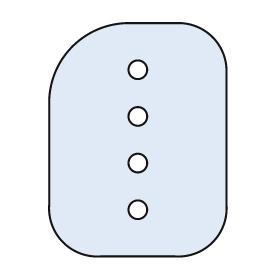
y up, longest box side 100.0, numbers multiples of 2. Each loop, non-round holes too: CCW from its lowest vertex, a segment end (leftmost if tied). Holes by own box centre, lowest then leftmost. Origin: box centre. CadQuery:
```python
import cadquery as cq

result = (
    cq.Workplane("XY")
    .moveTo(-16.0, -50.0)
    .lineTo(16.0, -50.0)
    .threePointArc((32.0, -44.0), (38.0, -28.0))
    .lineTo(38.0, 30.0)
    .threePointArc((32.0, 44.0), (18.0, 50.0))
    .lineTo(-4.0, 50.0)
    .threePointArc((-28.0, 40.0), (-38.0, 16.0))
    .lineTo(-38.0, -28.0)
    .threePointArc((-32.0, -44.0), (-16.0, -50.0))
    .close()
    .moveTo(0.0, -30.0)
    .circle(4.0)
    .moveTo(0.0, -10.0)
    .circle(4.0)
    .moveTo(0.0, 10.0)
    .circle(4.0)
    .moveTo(0.0, 30.0)
    .circle(4.0)
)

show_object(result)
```